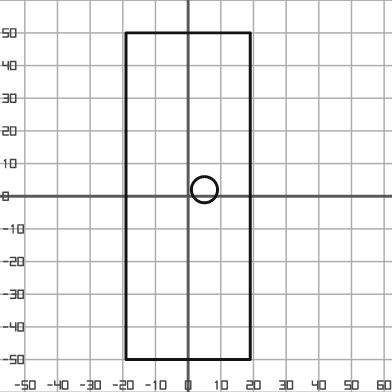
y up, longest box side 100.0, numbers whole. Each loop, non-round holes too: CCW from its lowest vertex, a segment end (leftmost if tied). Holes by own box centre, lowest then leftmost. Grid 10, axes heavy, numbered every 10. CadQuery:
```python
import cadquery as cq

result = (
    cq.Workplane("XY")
    .moveTo(-19.0, -50.0)
    .lineTo(19.0, -50.0)
    .lineTo(19.0, 50.0)
    .lineTo(-19.0, 50.0)
    .close()
    .moveTo(5.0, 2.0)
    .circle(4.0)
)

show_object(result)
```